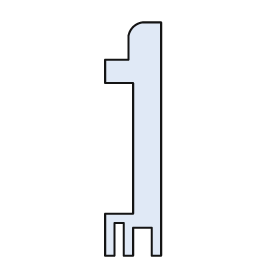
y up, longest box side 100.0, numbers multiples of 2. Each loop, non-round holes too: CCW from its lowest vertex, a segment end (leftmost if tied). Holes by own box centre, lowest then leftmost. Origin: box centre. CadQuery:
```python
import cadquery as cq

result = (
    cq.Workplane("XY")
    .moveTo(-12.0, -50.0)
    .lineTo(-8.0, -50.0)
    .lineTo(-8.0, -36.0)
    .lineTo(-4.0, -36.0)
    .lineTo(-4.0, -50.0)
    .lineTo(0.0, -50.0)
    .lineTo(0.0, -38.0)
    .lineTo(8.0, -38.0)
    .lineTo(8.0, -50.0)
    .lineTo(12.0, -50.0)
    .lineTo(12.0, 50.0)
    .lineTo(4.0, 50.0)
    .threePointArc((0.0, 48.0), (-2.0, 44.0))
    .lineTo(-2.0, 34.0)
    .lineTo(-12.0, 34.0)
    .lineTo(-12.0, 24.0)
    .lineTo(0.0, 24.0)
    .lineTo(0.0, -32.0)
    .lineTo(-12.0, -32.0)
    .close()
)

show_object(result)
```